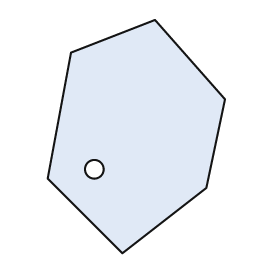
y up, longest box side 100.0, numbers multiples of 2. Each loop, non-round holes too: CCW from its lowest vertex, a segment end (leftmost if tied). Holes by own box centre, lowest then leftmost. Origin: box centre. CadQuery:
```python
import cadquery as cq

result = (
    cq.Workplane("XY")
    .moveTo(-6.0, -50.0)
    .lineTo(30.0, -22.0)
    .lineTo(38.0, 16.0)
    .lineTo(8.0, 50.0)
    .lineTo(-28.0, 36.0)
    .lineTo(-38.0, -18.0)
    .close()
    .moveTo(-18.0, -14.0)
    .circle(4.0)
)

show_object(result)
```